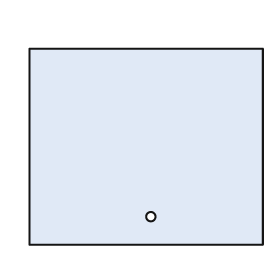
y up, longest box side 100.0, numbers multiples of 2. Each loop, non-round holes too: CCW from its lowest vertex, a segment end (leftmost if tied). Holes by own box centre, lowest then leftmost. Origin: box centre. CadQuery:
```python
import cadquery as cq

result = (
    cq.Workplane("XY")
    .moveTo(-50.0, -42.0)
    .lineTo(50.0, -42.0)
    .lineTo(50.0, 42.0)
    .lineTo(-50.0, 42.0)
    .close()
    .moveTo(2.0, -30.0)
    .circle(2.0)
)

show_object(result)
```